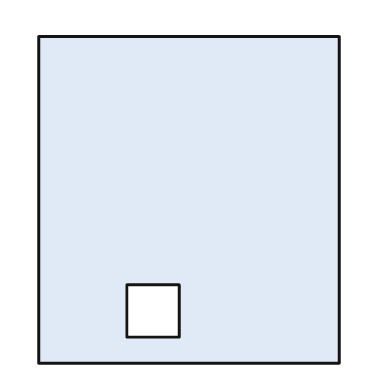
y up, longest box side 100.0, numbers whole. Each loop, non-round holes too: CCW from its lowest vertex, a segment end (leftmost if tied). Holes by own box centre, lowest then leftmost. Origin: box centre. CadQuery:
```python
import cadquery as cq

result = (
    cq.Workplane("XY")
    .moveTo(-46.0, -50.0)
    .lineTo(46.0, -50.0)
    .lineTo(46.0, 50.0)
    .lineTo(-46.0, 50.0)
    .close()
    .moveTo(-19.0, -42.0)
    .lineTo(-3.0, -42.0)
    .lineTo(-3.0, -26.0)
    .lineTo(-19.0, -26.0)
    .close()
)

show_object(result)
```